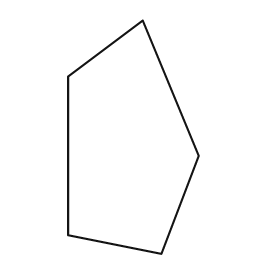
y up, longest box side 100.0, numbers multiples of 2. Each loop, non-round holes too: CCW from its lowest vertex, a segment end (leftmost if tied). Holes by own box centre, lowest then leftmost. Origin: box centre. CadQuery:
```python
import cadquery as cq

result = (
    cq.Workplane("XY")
    .moveTo(12.0, -50.0)
    .lineTo(28.0, -8.0)
    .lineTo(4.0, 50.0)
    .lineTo(-28.0, 26.0)
    .lineTo(-28.0, -42.0)
    .close()
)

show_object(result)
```